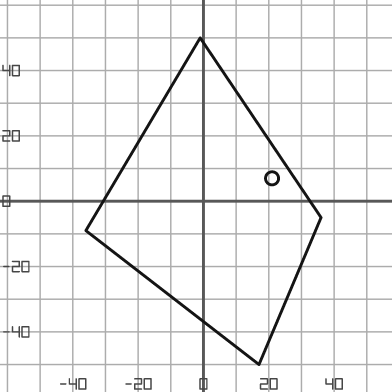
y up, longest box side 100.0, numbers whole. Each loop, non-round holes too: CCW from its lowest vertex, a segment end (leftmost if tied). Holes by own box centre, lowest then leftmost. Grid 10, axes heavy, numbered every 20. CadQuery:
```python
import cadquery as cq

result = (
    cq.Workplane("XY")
    .moveTo(17.0, -50.0)
    .lineTo(36.0, -5.0)
    .lineTo(-1.0, 50.0)
    .lineTo(-36.0, -9.0)
    .close()
    .moveTo(21.0, 7.0)
    .circle(2.0)
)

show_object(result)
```